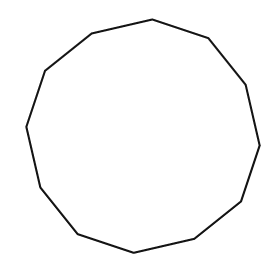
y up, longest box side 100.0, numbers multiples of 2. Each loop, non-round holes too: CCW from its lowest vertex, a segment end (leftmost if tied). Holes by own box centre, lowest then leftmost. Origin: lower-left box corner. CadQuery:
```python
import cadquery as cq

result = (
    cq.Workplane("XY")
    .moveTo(46.0, 0.0)
    .lineTo(72.0, 6.0)
    .lineTo(92.0, 22.0)
    .lineTo(100.0, 46.0)
    .lineTo(94.0, 72.0)
    .lineTo(78.0, 92.0)
    .lineTo(54.0, 100.0)
    .lineTo(28.0, 94.0)
    .lineTo(8.0, 78.0)
    .lineTo(0.0, 54.0)
    .lineTo(6.0, 28.0)
    .lineTo(22.0, 8.0)
    .close()
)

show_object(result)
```